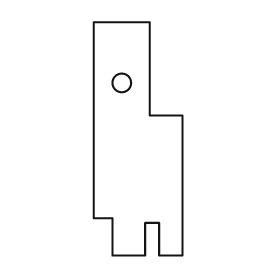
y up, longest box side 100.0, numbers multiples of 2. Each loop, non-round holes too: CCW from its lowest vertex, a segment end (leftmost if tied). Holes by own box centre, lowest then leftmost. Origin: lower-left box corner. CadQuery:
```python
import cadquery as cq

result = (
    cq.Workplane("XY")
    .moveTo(8.0, 0.0)
    .lineTo(22.0, 0.0)
    .lineTo(22.0, 14.0)
    .lineTo(28.0, 14.0)
    .lineTo(28.0, 0.0)
    .lineTo(38.0, 0.0)
    .lineTo(38.0, 60.0)
    .lineTo(24.0, 60.0)
    .lineTo(24.0, 100.0)
    .lineTo(0.0, 100.0)
    .lineTo(0.0, 16.0)
    .lineTo(8.0, 16.0)
    .close()
    .moveTo(12.0, 74.0)
    .circle(4.0)
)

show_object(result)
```